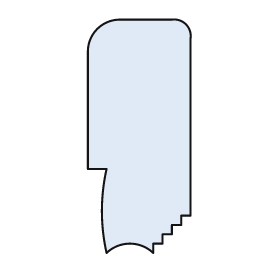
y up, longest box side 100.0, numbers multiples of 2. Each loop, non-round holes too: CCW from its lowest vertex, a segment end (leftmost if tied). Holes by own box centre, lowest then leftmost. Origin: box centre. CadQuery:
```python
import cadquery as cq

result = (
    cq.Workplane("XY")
    .moveTo(-14.0, -50.0)
    .threePointArc((-4.0, -46.0), (6.0, -50.0))
    .lineTo(6.0, -46.0)
    .lineTo(10.0, -46.0)
    .lineTo(10.0, -42.0)
    .lineTo(14.0, -42.0)
    .lineTo(14.0, -38.0)
    .lineTo(18.0, -38.0)
    .lineTo(18.0, -34.0)
    .lineTo(22.0, -34.0)
    .lineTo(22.0, 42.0)
    .threePointArc((20.0, 48.0), (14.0, 50.0))
    .lineTo(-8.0, 50.0)
    .threePointArc((-18.0, 46.0), (-22.0, 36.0))
    .lineTo(-22.0, -14.0)
    .lineTo(-14.0, -14.0)
    .threePointArc((-16.0, -32.0), (-14.0, -50.0))
    .close()
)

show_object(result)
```